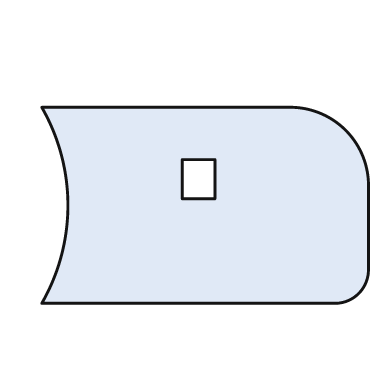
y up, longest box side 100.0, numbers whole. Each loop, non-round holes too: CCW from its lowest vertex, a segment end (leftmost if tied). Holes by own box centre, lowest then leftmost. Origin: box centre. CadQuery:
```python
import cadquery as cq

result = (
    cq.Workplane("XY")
    .moveTo(-50.0, -30.0)
    .lineTo(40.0, -30.0)
    .threePointArc((47.0, -27.0), (50.0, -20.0))
    .lineTo(50.0, 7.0)
    .threePointArc((43.0, 23.0), (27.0, 30.0))
    .lineTo(-50.0, 30.0)
    .threePointArc((-42.0, 0.0), (-50.0, -30.0))
    .close()
    .moveTo(-7.0, 2.0)
    .lineTo(3.0, 2.0)
    .lineTo(3.0, 14.0)
    .lineTo(-7.0, 14.0)
    .close()
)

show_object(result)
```